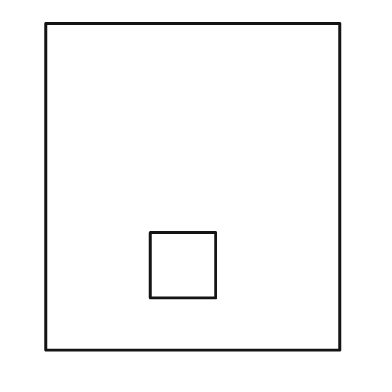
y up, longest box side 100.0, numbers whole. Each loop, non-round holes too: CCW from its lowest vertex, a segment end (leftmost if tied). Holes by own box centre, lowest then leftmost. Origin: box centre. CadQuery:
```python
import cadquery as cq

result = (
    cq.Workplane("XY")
    .moveTo(-45.0, -50.0)
    .lineTo(45.0, -50.0)
    .lineTo(45.0, 50.0)
    .lineTo(-45.0, 50.0)
    .close()
    .moveTo(-13.0, -34.0)
    .lineTo(7.0, -34.0)
    .lineTo(7.0, -14.0)
    .lineTo(-13.0, -14.0)
    .close()
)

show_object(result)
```